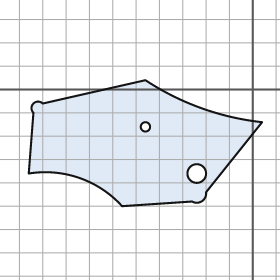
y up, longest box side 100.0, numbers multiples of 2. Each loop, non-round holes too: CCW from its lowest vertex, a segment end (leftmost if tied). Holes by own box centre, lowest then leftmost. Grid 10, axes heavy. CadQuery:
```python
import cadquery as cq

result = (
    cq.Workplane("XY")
    .moveTo(-56.0, -50.0)
    .lineTo(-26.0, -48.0)
    .threePointArc((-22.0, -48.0), (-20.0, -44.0))
    .lineTo(4.0, -14.0)
    .threePointArc((-22.0, -8.0), (-46.0, 4.0))
    .lineTo(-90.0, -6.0)
    .threePointArc((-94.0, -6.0), (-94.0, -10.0))
    .lineTo(-96.0, -36.0)
    .threePointArc((-74.0, -38.0), (-56.0, -50.0))
    .close()
    .moveTo(-24.0, -36.0)
    .circle(4.0)
    .moveTo(-46.0, -16.0)
    .circle(2.0)
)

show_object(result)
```